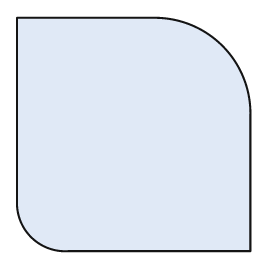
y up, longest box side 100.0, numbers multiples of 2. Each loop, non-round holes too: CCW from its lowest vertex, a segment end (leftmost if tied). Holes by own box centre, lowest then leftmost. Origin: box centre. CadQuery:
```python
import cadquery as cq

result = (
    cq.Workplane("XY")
    .moveTo(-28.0, -50.0)
    .lineTo(50.0, -50.0)
    .lineTo(50.0, 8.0)
    .threePointArc((38.0, 38.0), (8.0, 50.0))
    .lineTo(-50.0, 50.0)
    .lineTo(-50.0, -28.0)
    .threePointArc((-44.0, -44.0), (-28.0, -50.0))
    .close()
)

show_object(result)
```